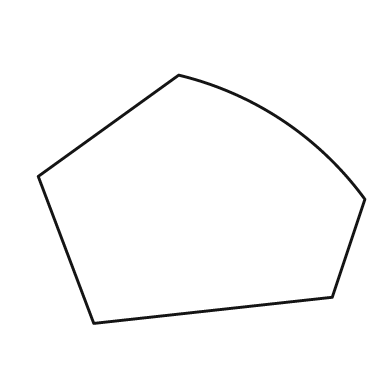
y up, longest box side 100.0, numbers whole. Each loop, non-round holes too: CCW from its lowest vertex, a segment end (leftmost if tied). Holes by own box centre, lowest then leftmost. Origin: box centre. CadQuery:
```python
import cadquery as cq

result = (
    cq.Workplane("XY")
    .moveTo(-33.0, -38.0)
    .lineTo(40.0, -30.0)
    .lineTo(50.0, 0.0)
    .threePointArc((25.0, 24.0), (-7.0, 38.0))
    .lineTo(-50.0, 7.0)
    .close()
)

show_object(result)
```